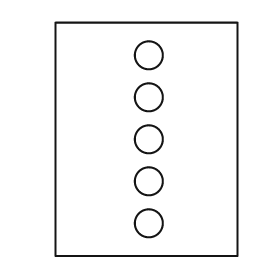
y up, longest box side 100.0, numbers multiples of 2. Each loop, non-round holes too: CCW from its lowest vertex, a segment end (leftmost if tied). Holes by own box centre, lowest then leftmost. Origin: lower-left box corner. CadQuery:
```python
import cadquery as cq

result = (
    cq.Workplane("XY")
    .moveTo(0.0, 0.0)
    .lineTo(78.0, 0.0)
    .lineTo(78.0, 100.0)
    .lineTo(0.0, 100.0)
    .close()
    .moveTo(40.0, 14.0)
    .circle(6.0)
    .moveTo(40.0, 32.0)
    .circle(6.0)
    .moveTo(40.0, 50.0)
    .circle(6.0)
    .moveTo(40.0, 68.0)
    .circle(6.0)
    .moveTo(40.0, 86.0)
    .circle(6.0)
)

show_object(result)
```